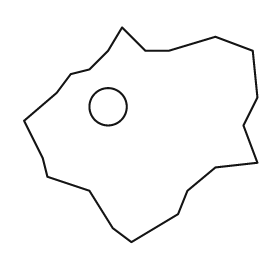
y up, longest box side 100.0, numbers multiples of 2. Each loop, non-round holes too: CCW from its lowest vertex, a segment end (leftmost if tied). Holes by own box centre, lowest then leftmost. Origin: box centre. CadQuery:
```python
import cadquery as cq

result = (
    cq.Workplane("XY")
    .moveTo(-4.0, -46.0)
    .lineTo(16.0, -34.0)
    .lineTo(20.0, -24.0)
    .lineTo(32.0, -14.0)
    .lineTo(50.0, -12.0)
    .lineTo(44.0, 4.0)
    .lineTo(50.0, 16.0)
    .lineTo(48.0, 36.0)
    .lineTo(32.0, 42.0)
    .lineTo(12.0, 36.0)
    .lineTo(2.0, 36.0)
    .lineTo(-8.0, 46.0)
    .lineTo(-14.0, 36.0)
    .lineTo(-22.0, 28.0)
    .lineTo(-30.0, 26.0)
    .lineTo(-36.0, 18.0)
    .lineTo(-50.0, 6.0)
    .lineTo(-42.0, -10.0)
    .lineTo(-40.0, -18.0)
    .lineTo(-22.0, -24.0)
    .lineTo(-12.0, -40.0)
    .close()
    .moveTo(-14.0, 12.0)
    .circle(8.0)
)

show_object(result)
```